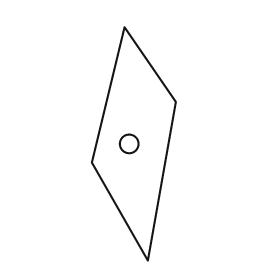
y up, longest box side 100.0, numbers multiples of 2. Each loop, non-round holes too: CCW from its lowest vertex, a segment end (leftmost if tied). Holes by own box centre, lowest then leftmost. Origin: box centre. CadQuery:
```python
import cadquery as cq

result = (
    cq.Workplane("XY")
    .moveTo(6.0, -50.0)
    .lineTo(18.0, 18.0)
    .lineTo(-4.0, 50.0)
    .lineTo(-18.0, -8.0)
    .close()
    .moveTo(-2.0, 0.0)
    .circle(4.0)
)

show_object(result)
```